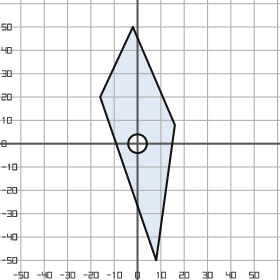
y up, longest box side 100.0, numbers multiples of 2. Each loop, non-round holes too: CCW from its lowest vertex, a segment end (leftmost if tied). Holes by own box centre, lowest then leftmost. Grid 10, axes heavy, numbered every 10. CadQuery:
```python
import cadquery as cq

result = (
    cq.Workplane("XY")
    .moveTo(8.0, -50.0)
    .lineTo(16.0, 8.0)
    .lineTo(-2.0, 50.0)
    .lineTo(-16.0, 20.0)
    .close()
    .moveTo(0.0, 0.0)
    .circle(4.0)
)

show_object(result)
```